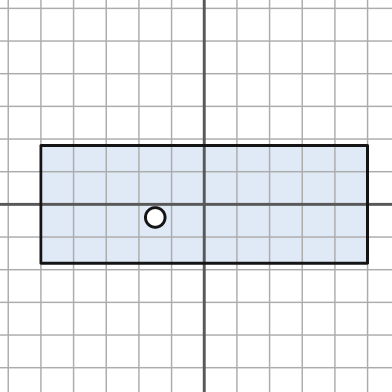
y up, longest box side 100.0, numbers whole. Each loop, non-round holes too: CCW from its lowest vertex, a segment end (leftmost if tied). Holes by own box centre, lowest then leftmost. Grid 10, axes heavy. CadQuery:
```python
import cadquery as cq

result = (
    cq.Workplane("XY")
    .moveTo(-50.0, -18.0)
    .lineTo(50.0, -18.0)
    .lineTo(50.0, 18.0)
    .lineTo(-50.0, 18.0)
    .close()
    .moveTo(-15.0, -4.0)
    .circle(3.0)
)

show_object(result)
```